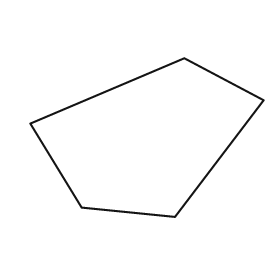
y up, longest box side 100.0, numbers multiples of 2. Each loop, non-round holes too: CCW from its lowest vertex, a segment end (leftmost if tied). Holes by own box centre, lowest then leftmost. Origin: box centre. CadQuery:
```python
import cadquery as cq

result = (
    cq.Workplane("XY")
    .moveTo(12.0, -34.0)
    .lineTo(50.0, 16.0)
    .lineTo(16.0, 34.0)
    .lineTo(-50.0, 6.0)
    .lineTo(-28.0, -30.0)
    .close()
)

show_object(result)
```